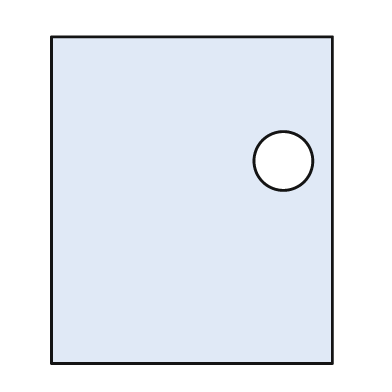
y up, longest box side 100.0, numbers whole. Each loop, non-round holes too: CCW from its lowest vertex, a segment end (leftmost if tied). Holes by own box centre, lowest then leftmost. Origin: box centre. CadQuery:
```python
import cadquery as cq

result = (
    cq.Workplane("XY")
    .moveTo(-43.0, -50.0)
    .lineTo(43.0, -50.0)
    .lineTo(43.0, 50.0)
    .lineTo(-43.0, 50.0)
    .close()
    .moveTo(28.0, 12.0)
    .circle(9.0)
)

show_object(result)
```